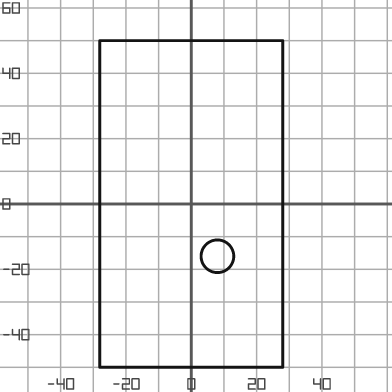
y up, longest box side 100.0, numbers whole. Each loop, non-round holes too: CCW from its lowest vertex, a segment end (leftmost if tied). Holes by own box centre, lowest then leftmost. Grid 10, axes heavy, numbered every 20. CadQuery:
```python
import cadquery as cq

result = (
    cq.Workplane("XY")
    .moveTo(-28.0, -50.0)
    .lineTo(28.0, -50.0)
    .lineTo(28.0, 50.0)
    .lineTo(-28.0, 50.0)
    .close()
    .moveTo(8.0, -16.0)
    .circle(5.0)
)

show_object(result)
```